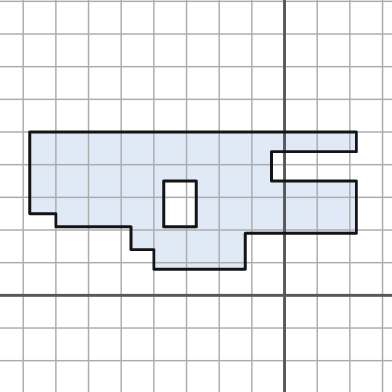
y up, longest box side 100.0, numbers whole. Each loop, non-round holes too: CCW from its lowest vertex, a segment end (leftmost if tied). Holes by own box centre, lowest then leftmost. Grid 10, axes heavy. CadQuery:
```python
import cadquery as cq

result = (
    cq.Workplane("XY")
    .moveTo(-40.0, 8.0)
    .lineTo(-12.0, 8.0)
    .lineTo(-12.0, 19.0)
    .lineTo(22.0, 19.0)
    .lineTo(22.0, 35.0)
    .lineTo(-4.0, 35.0)
    .lineTo(-4.0, 44.0)
    .lineTo(22.0, 44.0)
    .lineTo(22.0, 50.0)
    .lineTo(-78.0, 50.0)
    .lineTo(-78.0, 25.0)
    .lineTo(-70.0, 25.0)
    .lineTo(-70.0, 21.0)
    .lineTo(-47.0, 21.0)
    .lineTo(-47.0, 14.0)
    .lineTo(-40.0, 14.0)
    .close()
    .moveTo(-37.0, 21.0)
    .lineTo(-27.0, 21.0)
    .lineTo(-27.0, 35.0)
    .lineTo(-37.0, 35.0)
    .close()
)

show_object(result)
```